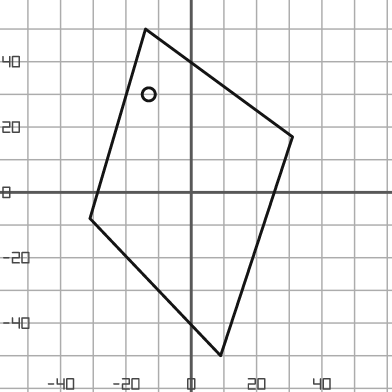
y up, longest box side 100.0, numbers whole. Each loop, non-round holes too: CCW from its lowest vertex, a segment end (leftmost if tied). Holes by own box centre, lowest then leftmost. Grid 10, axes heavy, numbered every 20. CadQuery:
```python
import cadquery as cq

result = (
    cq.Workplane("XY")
    .moveTo(9.0, -50.0)
    .lineTo(31.0, 17.0)
    .lineTo(-14.0, 50.0)
    .lineTo(-31.0, -8.0)
    .close()
    .moveTo(-13.0, 30.0)
    .circle(2.0)
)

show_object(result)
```